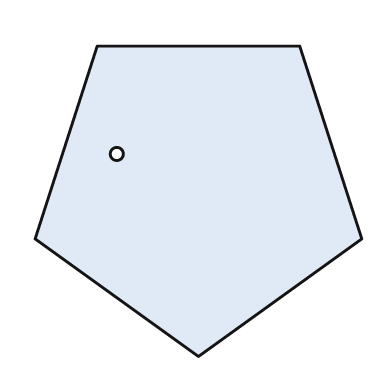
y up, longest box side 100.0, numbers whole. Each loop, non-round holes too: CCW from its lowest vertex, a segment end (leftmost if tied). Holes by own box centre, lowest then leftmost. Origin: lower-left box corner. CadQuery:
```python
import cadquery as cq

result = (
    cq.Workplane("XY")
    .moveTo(50.0, 0.0)
    .lineTo(100.0, 36.0)
    .lineTo(81.0, 95.0)
    .lineTo(19.0, 95.0)
    .lineTo(0.0, 36.0)
    .close()
    .moveTo(25.0, 62.0)
    .circle(2.0)
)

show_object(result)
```